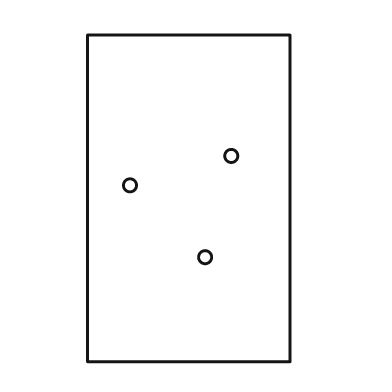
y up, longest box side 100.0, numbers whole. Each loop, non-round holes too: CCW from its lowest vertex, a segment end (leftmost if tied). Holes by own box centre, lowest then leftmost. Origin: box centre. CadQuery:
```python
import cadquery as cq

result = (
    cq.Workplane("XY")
    .moveTo(-31.0, -50.0)
    .lineTo(31.0, -50.0)
    .lineTo(31.0, 50.0)
    .lineTo(-31.0, 50.0)
    .close()
    .moveTo(5.0, -18.0)
    .circle(2.0)
    .moveTo(-18.0, 4.0)
    .circle(2.0)
    .moveTo(13.0, 13.0)
    .circle(2.0)
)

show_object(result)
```